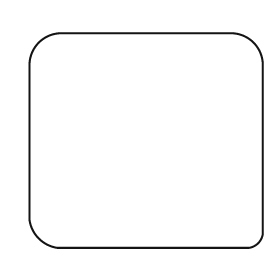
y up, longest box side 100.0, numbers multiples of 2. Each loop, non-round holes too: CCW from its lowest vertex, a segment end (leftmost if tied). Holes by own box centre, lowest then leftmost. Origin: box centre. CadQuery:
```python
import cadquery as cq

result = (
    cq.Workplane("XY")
    .moveTo(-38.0, -46.0)
    .lineTo(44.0, -46.0)
    .threePointArc((48.0, -44.0), (50.0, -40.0))
    .lineTo(50.0, 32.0)
    .threePointArc((46.0, 42.0), (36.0, 46.0))
    .lineTo(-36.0, 46.0)
    .threePointArc((-46.0, 42.0), (-50.0, 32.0))
    .lineTo(-50.0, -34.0)
    .threePointArc((-46.0, -42.0), (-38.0, -46.0))
    .close()
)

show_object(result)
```